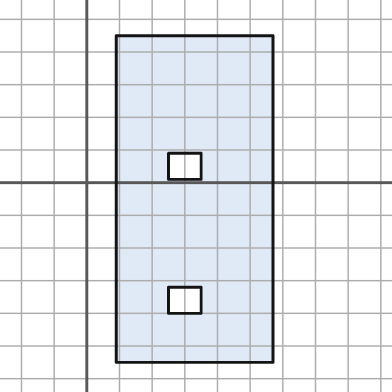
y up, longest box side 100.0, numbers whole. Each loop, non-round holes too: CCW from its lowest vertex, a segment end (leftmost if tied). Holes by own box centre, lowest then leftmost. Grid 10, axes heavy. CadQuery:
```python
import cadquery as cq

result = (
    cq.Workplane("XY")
    .moveTo(9.0, -55.0)
    .lineTo(57.0, -55.0)
    .lineTo(57.0, 45.0)
    .lineTo(9.0, 45.0)
    .close()
    .moveTo(25.0, -40.0)
    .lineTo(35.0, -40.0)
    .lineTo(35.0, -32.0)
    .lineTo(25.0, -32.0)
    .close()
    .moveTo(25.0, 1.0)
    .lineTo(35.0, 1.0)
    .lineTo(35.0, 9.0)
    .lineTo(25.0, 9.0)
    .close()
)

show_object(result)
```